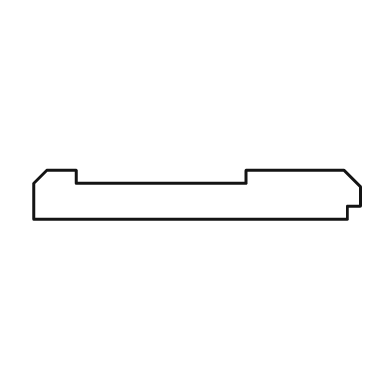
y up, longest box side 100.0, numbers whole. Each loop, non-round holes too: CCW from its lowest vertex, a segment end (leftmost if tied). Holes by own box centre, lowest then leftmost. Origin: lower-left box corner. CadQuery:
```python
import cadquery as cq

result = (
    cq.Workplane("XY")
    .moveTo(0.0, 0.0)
    .lineTo(96.0, 0.0)
    .lineTo(96.0, 4.0)
    .lineTo(100.0, 4.0)
    .lineTo(100.0, 10.0)
    .lineTo(95.0, 15.0)
    .lineTo(65.0, 15.0)
    .lineTo(65.0, 11.0)
    .lineTo(13.0, 11.0)
    .lineTo(13.0, 15.0)
    .lineTo(4.0, 15.0)
    .lineTo(0.0, 11.0)
    .close()
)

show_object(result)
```